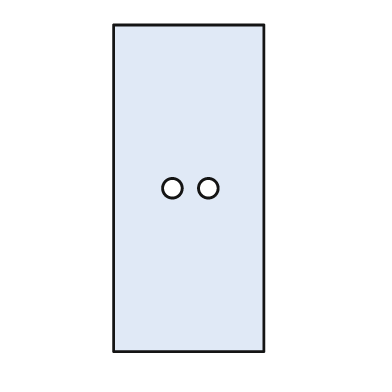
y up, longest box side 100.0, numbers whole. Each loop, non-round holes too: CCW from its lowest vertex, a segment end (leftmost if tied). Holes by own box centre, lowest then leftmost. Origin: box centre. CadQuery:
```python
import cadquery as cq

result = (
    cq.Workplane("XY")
    .moveTo(-23.0, -50.0)
    .lineTo(23.0, -50.0)
    .lineTo(23.0, 50.0)
    .lineTo(-23.0, 50.0)
    .close()
    .moveTo(-5.0, 0.0)
    .circle(3.0)
    .moveTo(6.0, 0.0)
    .circle(3.0)
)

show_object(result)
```